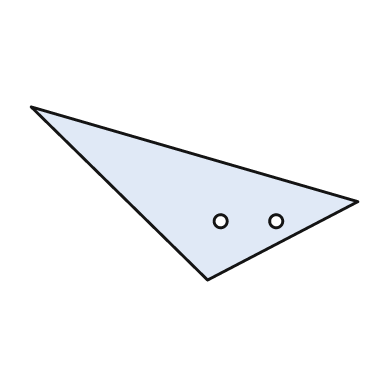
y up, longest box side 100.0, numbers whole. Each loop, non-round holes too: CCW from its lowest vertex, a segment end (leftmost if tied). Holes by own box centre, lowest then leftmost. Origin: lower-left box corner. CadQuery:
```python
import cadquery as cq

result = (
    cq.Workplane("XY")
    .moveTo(54.0, 0.0)
    .lineTo(100.0, 24.0)
    .lineTo(0.0, 53.0)
    .close()
    .moveTo(58.0, 18.0)
    .circle(2.0)
    .moveTo(75.0, 18.0)
    .circle(2.0)
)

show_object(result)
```